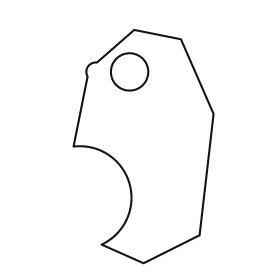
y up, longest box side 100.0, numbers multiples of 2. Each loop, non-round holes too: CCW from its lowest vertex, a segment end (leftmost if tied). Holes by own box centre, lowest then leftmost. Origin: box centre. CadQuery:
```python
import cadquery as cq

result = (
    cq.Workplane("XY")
    .moveTo(0.0, -50.0)
    .lineTo(24.0, -38.0)
    .lineTo(30.0, 14.0)
    .lineTo(16.0, 46.0)
    .lineTo(-4.0, 50.0)
    .lineTo(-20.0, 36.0)
    .threePointArc((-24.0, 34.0), (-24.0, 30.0))
    .lineTo(-30.0, 0.0)
    .threePointArc((-6.0, -16.0), (-18.0, -42.0))
    .close()
    .moveTo(-6.0, 32.0)
    .circle(8.0)
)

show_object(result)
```